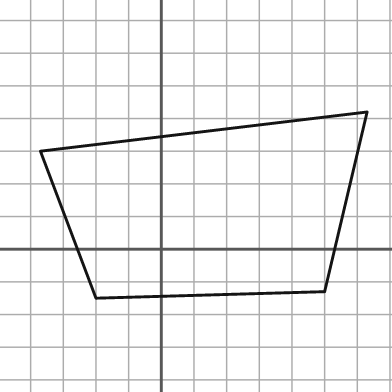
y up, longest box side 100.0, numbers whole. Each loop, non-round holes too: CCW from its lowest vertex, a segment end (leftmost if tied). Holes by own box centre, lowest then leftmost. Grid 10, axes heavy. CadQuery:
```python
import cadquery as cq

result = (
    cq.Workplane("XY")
    .moveTo(-20.0, -15.0)
    .lineTo(50.0, -13.0)
    .lineTo(63.0, 42.0)
    .lineTo(-37.0, 30.0)
    .close()
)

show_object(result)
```